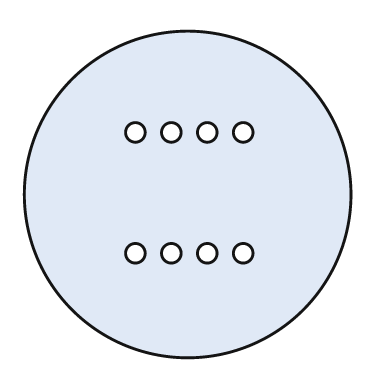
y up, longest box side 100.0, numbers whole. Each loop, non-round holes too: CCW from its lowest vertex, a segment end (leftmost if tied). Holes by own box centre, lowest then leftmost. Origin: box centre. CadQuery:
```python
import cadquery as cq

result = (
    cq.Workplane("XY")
    .moveTo(0.0, 0.0)
    .circle(50.0)
    .moveTo(-16.0, -18.0)
    .circle(3.0)
    .moveTo(-5.0, -18.0)
    .circle(3.0)
    .moveTo(6.0, -18.0)
    .circle(3.0)
    .moveTo(17.0, -18.0)
    .circle(3.0)
    .moveTo(-16.0, 19.0)
    .circle(3.0)
    .moveTo(-5.0, 19.0)
    .circle(3.0)
    .moveTo(6.0, 19.0)
    .circle(3.0)
    .moveTo(17.0, 19.0)
    .circle(3.0)
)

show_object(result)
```